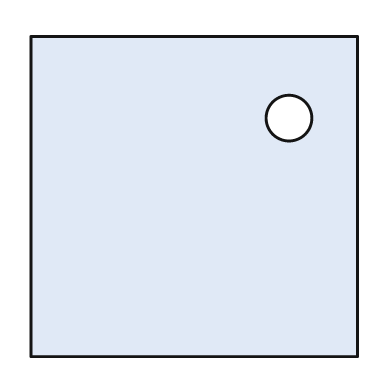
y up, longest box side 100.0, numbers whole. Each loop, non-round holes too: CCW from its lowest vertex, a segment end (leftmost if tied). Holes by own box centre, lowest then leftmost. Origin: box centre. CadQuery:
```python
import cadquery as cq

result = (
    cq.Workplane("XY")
    .moveTo(-50.0, -49.0)
    .lineTo(50.0, -49.0)
    .lineTo(50.0, 49.0)
    .lineTo(-50.0, 49.0)
    .close()
    .moveTo(29.0, 24.0)
    .circle(7.0)
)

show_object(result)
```